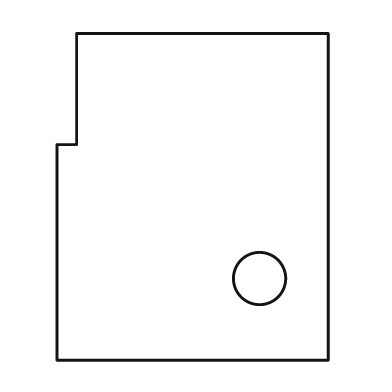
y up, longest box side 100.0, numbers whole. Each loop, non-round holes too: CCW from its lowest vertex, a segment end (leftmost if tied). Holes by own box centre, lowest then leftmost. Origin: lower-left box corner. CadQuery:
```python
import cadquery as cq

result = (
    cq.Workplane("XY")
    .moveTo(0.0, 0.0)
    .lineTo(83.0, 0.0)
    .lineTo(83.0, 100.0)
    .lineTo(6.0, 100.0)
    .lineTo(6.0, 66.0)
    .lineTo(0.0, 66.0)
    .close()
    .moveTo(62.0, 25.0)
    .circle(8.0)
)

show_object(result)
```